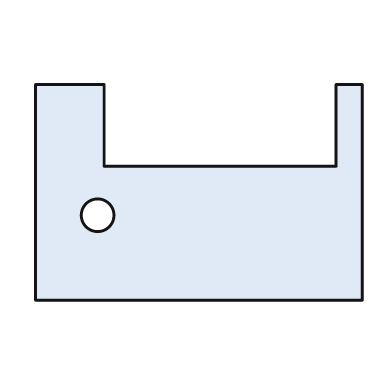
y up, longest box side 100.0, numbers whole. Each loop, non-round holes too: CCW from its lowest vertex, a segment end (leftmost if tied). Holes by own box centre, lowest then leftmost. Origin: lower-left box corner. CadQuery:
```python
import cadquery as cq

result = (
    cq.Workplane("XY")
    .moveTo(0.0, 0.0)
    .lineTo(100.0, 0.0)
    .lineTo(100.0, 66.0)
    .lineTo(92.0, 66.0)
    .lineTo(92.0, 41.0)
    .lineTo(21.0, 41.0)
    .lineTo(21.0, 66.0)
    .lineTo(0.0, 66.0)
    .close()
    .moveTo(19.0, 26.0)
    .circle(5.0)
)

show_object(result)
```